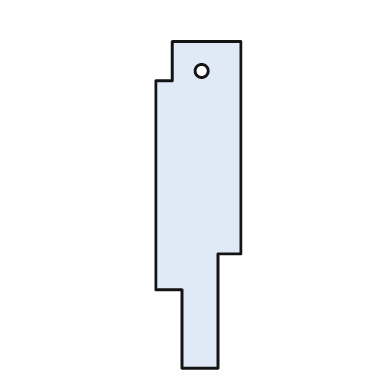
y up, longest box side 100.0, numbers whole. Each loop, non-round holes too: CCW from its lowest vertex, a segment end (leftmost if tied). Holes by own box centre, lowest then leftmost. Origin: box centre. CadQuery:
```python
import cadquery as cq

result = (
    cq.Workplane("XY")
    .moveTo(-5.0, -50.0)
    .lineTo(6.0, -50.0)
    .lineTo(6.0, -15.0)
    .lineTo(13.0, -15.0)
    .lineTo(13.0, 50.0)
    .lineTo(-8.0, 50.0)
    .lineTo(-8.0, 38.0)
    .lineTo(-13.0, 38.0)
    .lineTo(-13.0, -26.0)
    .lineTo(-5.0, -26.0)
    .close()
    .moveTo(1.0, 41.0)
    .circle(2.0)
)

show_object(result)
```